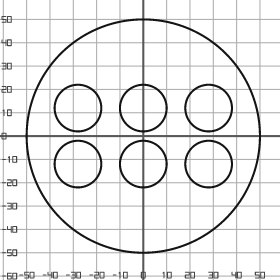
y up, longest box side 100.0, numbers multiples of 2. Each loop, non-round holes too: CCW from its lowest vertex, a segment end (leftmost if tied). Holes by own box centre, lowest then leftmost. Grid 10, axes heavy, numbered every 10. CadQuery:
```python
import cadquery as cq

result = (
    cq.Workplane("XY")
    .moveTo(0.0, 0.0)
    .circle(50.0)
    .moveTo(-28.0, -12.0)
    .circle(10.0)
    .moveTo(0.0, -12.0)
    .circle(10.0)
    .moveTo(28.0, -12.0)
    .circle(10.0)
    .moveTo(-28.0, 12.0)
    .circle(10.0)
    .moveTo(0.0, 12.0)
    .circle(10.0)
    .moveTo(28.0, 12.0)
    .circle(10.0)
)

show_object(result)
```